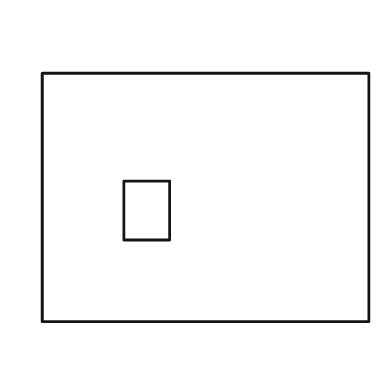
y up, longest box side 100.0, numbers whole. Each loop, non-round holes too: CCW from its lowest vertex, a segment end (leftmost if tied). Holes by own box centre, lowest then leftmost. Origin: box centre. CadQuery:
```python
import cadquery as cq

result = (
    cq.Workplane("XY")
    .moveTo(-50.0, -38.0)
    .lineTo(50.0, -38.0)
    .lineTo(50.0, 38.0)
    .lineTo(-50.0, 38.0)
    .close()
    .moveTo(-25.0, -13.0)
    .lineTo(-11.0, -13.0)
    .lineTo(-11.0, 5.0)
    .lineTo(-25.0, 5.0)
    .close()
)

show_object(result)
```